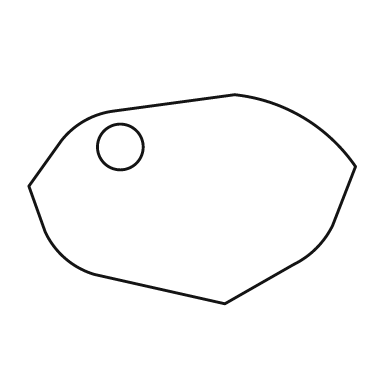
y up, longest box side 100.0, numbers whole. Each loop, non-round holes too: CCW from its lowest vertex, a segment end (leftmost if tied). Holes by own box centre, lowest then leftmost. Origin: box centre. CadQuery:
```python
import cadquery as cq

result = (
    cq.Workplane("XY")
    .moveTo(10.0, -32.0)
    .lineTo(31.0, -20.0)
    .threePointArc((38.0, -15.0), (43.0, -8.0))
    .lineTo(50.0, 10.0)
    .threePointArc((34.0, 25.0), (13.0, 32.0))
    .lineTo(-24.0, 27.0)
    .threePointArc((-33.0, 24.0), (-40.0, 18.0))
    .lineTo(-50.0, 4.0)
    .lineTo(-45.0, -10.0)
    .threePointArc((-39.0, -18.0), (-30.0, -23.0))
    .close()
    .moveTo(-22.0, 16.0)
    .circle(7.0)
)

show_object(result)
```